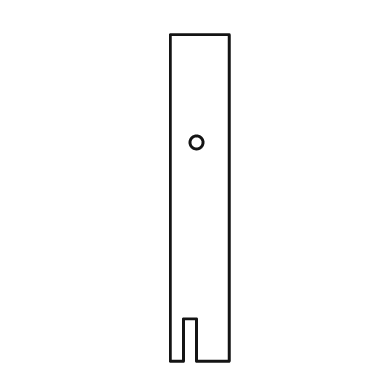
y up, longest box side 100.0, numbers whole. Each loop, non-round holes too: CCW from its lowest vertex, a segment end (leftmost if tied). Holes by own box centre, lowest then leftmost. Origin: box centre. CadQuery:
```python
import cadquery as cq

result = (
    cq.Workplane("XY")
    .moveTo(-9.0, -50.0)
    .lineTo(-5.0, -50.0)
    .lineTo(-5.0, -37.0)
    .lineTo(-1.0, -37.0)
    .lineTo(-1.0, -50.0)
    .lineTo(9.0, -50.0)
    .lineTo(9.0, 50.0)
    .lineTo(-9.0, 50.0)
    .close()
    .moveTo(-1.0, 17.0)
    .circle(2.0)
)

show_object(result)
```